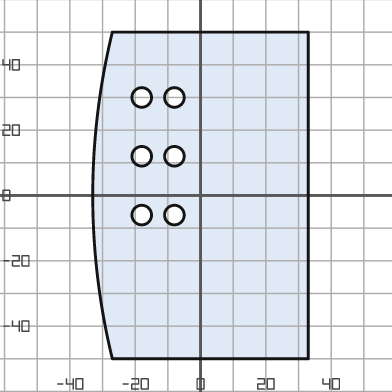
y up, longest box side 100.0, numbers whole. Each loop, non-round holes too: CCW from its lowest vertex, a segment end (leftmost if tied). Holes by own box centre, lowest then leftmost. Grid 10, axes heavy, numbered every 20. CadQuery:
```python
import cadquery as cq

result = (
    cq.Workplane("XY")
    .moveTo(-27.0, -50.0)
    .lineTo(33.0, -50.0)
    .lineTo(33.0, 50.0)
    .lineTo(-27.0, 50.0)
    .threePointArc((-33.0, 0.0), (-27.0, -50.0))
    .close()
    .moveTo(-18.0, -6.0)
    .circle(3.0)
    .moveTo(-8.0, -6.0)
    .circle(3.0)
    .moveTo(-18.0, 12.0)
    .circle(3.0)
    .moveTo(-8.0, 12.0)
    .circle(3.0)
    .moveTo(-18.0, 30.0)
    .circle(3.0)
    .moveTo(-8.0, 30.0)
    .circle(3.0)
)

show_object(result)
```